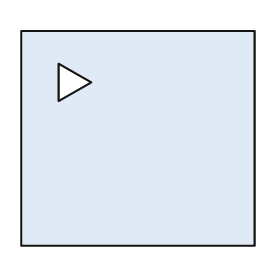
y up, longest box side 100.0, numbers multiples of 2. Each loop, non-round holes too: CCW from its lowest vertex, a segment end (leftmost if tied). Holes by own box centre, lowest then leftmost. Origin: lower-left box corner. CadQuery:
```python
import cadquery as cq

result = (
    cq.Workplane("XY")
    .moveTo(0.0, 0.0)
    .lineTo(100.0, 0.0)
    .lineTo(100.0, 92.0)
    .lineTo(0.0, 92.0)
    .close()
    .moveTo(16.0, 62.0)
    .lineTo(30.0, 70.0)
    .lineTo(16.0, 78.0)
    .close()
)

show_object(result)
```